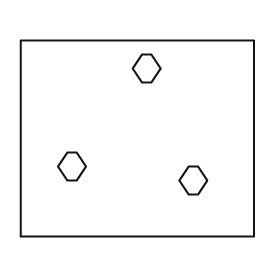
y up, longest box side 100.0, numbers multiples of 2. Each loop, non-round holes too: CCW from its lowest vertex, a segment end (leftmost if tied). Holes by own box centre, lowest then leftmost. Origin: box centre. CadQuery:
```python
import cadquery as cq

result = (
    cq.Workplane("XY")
    .moveTo(-50.0, -42.0)
    .lineTo(50.0, -42.0)
    .lineTo(50.0, 42.0)
    .lineTo(-50.0, 42.0)
    .close()
    .moveTo(22.0, -24.0)
    .lineTo(26.0, -24.0)
    .lineTo(30.0, -18.0)
    .lineTo(26.0, -12.0)
    .lineTo(22.0, -12.0)
    .lineTo(18.0, -18.0)
    .close()
    .moveTo(-30.0, -18.0)
    .lineTo(-26.0, -18.0)
    .lineTo(-22.0, -12.0)
    .lineTo(-26.0, -6.0)
    .lineTo(-30.0, -6.0)
    .lineTo(-34.0, -12.0)
    .close()
    .moveTo(2.0, 24.0)
    .lineTo(6.0, 24.0)
    .lineTo(10.0, 30.0)
    .lineTo(6.0, 36.0)
    .lineTo(2.0, 36.0)
    .lineTo(-2.0, 30.0)
    .close()
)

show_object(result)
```